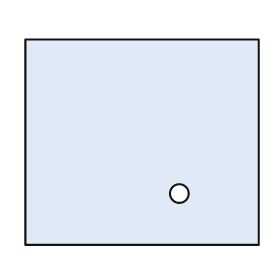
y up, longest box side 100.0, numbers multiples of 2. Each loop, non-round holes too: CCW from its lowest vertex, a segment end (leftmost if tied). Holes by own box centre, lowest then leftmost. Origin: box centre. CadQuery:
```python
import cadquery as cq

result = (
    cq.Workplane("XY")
    .moveTo(-50.0, -44.0)
    .lineTo(50.0, -44.0)
    .lineTo(50.0, 44.0)
    .lineTo(-50.0, 44.0)
    .close()
    .moveTo(16.0, -22.0)
    .circle(4.0)
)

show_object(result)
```